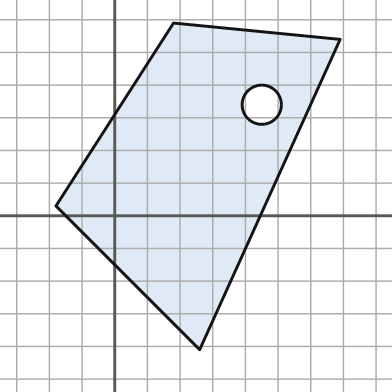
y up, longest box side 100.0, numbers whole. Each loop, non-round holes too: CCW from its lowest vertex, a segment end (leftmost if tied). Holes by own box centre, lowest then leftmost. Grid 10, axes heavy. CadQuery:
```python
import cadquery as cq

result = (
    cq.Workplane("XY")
    .moveTo(26.0, -41.0)
    .lineTo(69.0, 54.0)
    .lineTo(18.0, 59.0)
    .lineTo(-18.0, 3.0)
    .close()
    .moveTo(45.0, 34.0)
    .circle(6.0)
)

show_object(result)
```